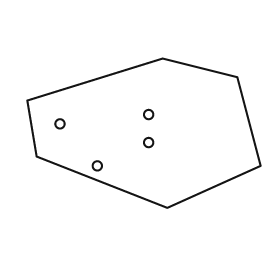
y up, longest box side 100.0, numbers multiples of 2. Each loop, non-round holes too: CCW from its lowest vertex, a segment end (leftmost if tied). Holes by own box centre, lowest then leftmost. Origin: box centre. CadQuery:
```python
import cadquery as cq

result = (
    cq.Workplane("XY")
    .moveTo(10.0, -32.0)
    .lineTo(50.0, -14.0)
    .lineTo(40.0, 24.0)
    .lineTo(8.0, 32.0)
    .lineTo(-50.0, 14.0)
    .lineTo(-46.0, -10.0)
    .close()
    .moveTo(-20.0, -14.0)
    .circle(2.0)
    .moveTo(2.0, -4.0)
    .circle(2.0)
    .moveTo(-36.0, 4.0)
    .circle(2.0)
    .moveTo(2.0, 8.0)
    .circle(2.0)
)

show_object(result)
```